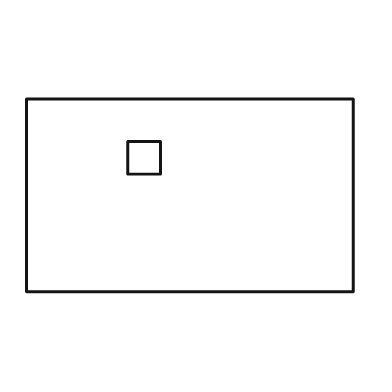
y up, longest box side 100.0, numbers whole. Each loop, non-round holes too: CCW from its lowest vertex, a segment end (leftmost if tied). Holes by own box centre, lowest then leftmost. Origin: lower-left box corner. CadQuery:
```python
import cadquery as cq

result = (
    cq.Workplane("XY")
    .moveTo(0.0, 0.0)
    .lineTo(100.0, 0.0)
    .lineTo(100.0, 59.0)
    .lineTo(0.0, 59.0)
    .close()
    .moveTo(31.0, 36.0)
    .lineTo(41.0, 36.0)
    .lineTo(41.0, 46.0)
    .lineTo(31.0, 46.0)
    .close()
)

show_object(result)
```